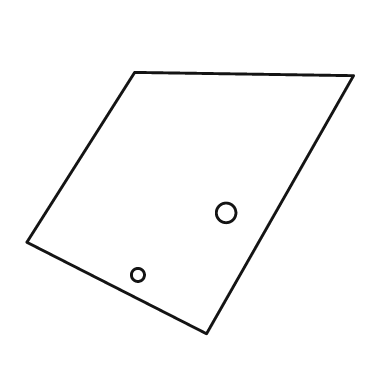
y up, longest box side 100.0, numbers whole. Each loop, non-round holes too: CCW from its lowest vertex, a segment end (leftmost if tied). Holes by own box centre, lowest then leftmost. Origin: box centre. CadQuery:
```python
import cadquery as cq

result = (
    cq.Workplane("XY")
    .moveTo(5.0, -40.0)
    .lineTo(50.0, 39.0)
    .lineTo(-17.0, 40.0)
    .lineTo(-50.0, -12.0)
    .close()
    .moveTo(-16.0, -22.0)
    .circle(2.0)
    .moveTo(11.0, -3.0)
    .circle(3.0)
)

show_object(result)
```